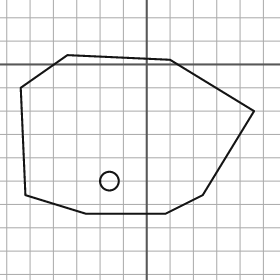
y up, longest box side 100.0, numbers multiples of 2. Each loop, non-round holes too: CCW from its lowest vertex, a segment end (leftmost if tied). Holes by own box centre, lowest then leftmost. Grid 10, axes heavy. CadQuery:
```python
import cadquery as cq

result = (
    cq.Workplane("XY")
    .moveTo(-26.0, -64.0)
    .lineTo(8.0, -64.0)
    .lineTo(24.0, -56.0)
    .lineTo(46.0, -20.0)
    .lineTo(10.0, 2.0)
    .lineTo(-34.0, 4.0)
    .lineTo(-54.0, -10.0)
    .lineTo(-52.0, -56.0)
    .close()
    .moveTo(-16.0, -50.0)
    .circle(4.0)
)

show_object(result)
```